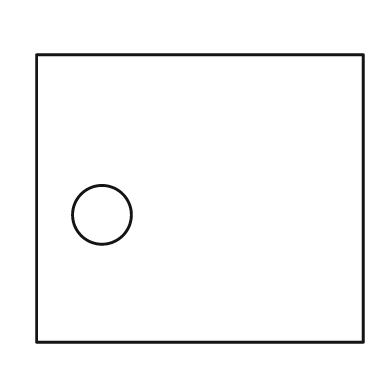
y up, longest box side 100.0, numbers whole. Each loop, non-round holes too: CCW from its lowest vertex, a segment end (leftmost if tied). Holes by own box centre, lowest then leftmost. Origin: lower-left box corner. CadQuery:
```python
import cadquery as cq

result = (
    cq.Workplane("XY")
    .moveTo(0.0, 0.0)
    .lineTo(100.0, 0.0)
    .lineTo(100.0, 88.0)
    .lineTo(0.0, 88.0)
    .close()
    .moveTo(20.0, 39.0)
    .circle(9.0)
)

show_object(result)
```